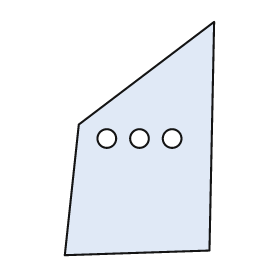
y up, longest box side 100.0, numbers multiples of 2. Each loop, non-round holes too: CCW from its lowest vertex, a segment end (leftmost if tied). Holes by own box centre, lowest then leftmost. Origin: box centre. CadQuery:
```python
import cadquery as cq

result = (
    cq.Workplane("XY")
    .moveTo(-32.0, -50.0)
    .lineTo(30.0, -48.0)
    .lineTo(32.0, 50.0)
    .lineTo(-26.0, 6.0)
    .close()
    .moveTo(-14.0, 0.0)
    .circle(4.0)
    .moveTo(0.0, 0.0)
    .circle(4.0)
    .moveTo(14.0, 0.0)
    .circle(4.0)
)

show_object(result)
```